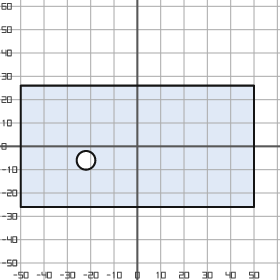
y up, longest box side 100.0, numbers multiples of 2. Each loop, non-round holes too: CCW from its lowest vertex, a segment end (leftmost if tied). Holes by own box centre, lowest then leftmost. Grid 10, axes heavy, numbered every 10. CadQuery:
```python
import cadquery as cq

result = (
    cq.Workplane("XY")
    .moveTo(-50.0, -26.0)
    .lineTo(50.0, -26.0)
    .lineTo(50.0, 26.0)
    .lineTo(-50.0, 26.0)
    .close()
    .moveTo(-22.0, -6.0)
    .circle(4.0)
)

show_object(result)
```